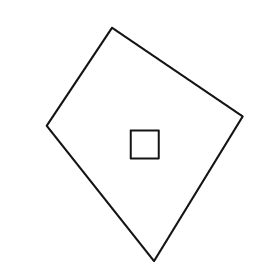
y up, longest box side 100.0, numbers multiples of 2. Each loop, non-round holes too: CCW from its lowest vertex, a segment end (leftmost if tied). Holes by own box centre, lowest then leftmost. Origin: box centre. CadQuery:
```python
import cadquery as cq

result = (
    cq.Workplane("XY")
    .moveTo(4.0, -50.0)
    .lineTo(42.0, 12.0)
    .lineTo(-14.0, 50.0)
    .lineTo(-42.0, 8.0)
    .close()
    .moveTo(-6.0, -6.0)
    .lineTo(6.0, -6.0)
    .lineTo(6.0, 6.0)
    .lineTo(-6.0, 6.0)
    .close()
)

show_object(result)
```